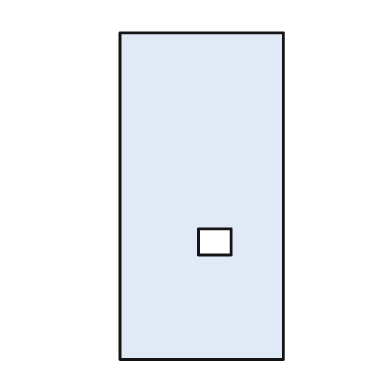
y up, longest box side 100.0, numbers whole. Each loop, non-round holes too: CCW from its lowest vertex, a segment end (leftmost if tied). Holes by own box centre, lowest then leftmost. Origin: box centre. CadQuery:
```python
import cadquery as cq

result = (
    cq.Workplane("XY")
    .moveTo(-25.0, -50.0)
    .lineTo(25.0, -50.0)
    .lineTo(25.0, 50.0)
    .lineTo(-25.0, 50.0)
    .close()
    .moveTo(-1.0, -18.0)
    .lineTo(9.0, -18.0)
    .lineTo(9.0, -10.0)
    .lineTo(-1.0, -10.0)
    .close()
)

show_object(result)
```